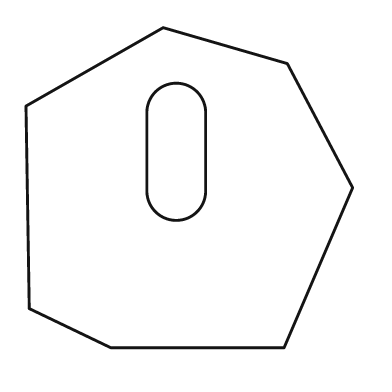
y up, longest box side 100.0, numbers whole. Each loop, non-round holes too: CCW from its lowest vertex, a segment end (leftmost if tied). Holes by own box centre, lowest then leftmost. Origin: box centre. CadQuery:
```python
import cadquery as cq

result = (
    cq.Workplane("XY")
    .moveTo(-24.0, -49.0)
    .lineTo(29.0, -49.0)
    .lineTo(50.0, 0.0)
    .lineTo(30.0, 38.0)
    .lineTo(-8.0, 49.0)
    .lineTo(-50.0, 25.0)
    .lineTo(-49.0, -37.0)
    .close()
    .moveTo(-13.0, -1.0)
    .threePointArc((-4.0, -10.0), (5.0, -1.0))
    .lineTo(5.0, 23.0)
    .threePointArc((-4.0, 32.0), (-13.0, 23.0))
    .close()
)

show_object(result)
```